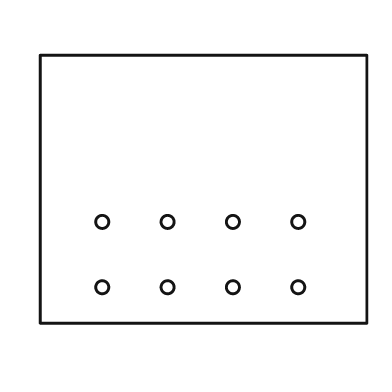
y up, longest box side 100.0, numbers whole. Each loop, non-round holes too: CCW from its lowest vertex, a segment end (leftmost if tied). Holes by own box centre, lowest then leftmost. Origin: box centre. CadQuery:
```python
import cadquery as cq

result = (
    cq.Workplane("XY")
    .moveTo(-50.0, -41.0)
    .lineTo(50.0, -41.0)
    .lineTo(50.0, 41.0)
    .lineTo(-50.0, 41.0)
    .close()
    .moveTo(-31.0, -30.0)
    .circle(2.0)
    .moveTo(-11.0, -30.0)
    .circle(2.0)
    .moveTo(9.0, -30.0)
    .circle(2.0)
    .moveTo(29.0, -30.0)
    .circle(2.0)
    .moveTo(-31.0, -10.0)
    .circle(2.0)
    .moveTo(-11.0, -10.0)
    .circle(2.0)
    .moveTo(9.0, -10.0)
    .circle(2.0)
    .moveTo(29.0, -10.0)
    .circle(2.0)
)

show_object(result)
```